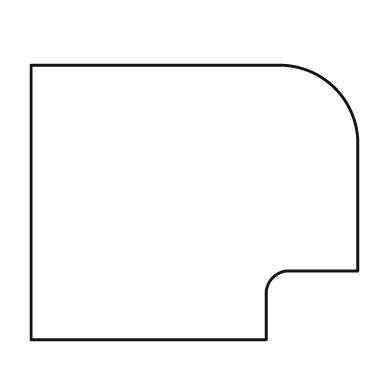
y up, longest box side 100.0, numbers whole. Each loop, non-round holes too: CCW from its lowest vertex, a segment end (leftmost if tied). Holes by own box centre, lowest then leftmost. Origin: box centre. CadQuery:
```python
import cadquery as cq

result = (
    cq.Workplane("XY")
    .moveTo(-50.0, -42.0)
    .lineTo(22.0, -42.0)
    .lineTo(22.0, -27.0)
    .threePointArc((24.0, -23.0), (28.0, -21.0))
    .lineTo(50.0, -21.0)
    .lineTo(50.0, 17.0)
    .threePointArc((43.0, 35.0), (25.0, 42.0))
    .lineTo(-50.0, 42.0)
    .close()
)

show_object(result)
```